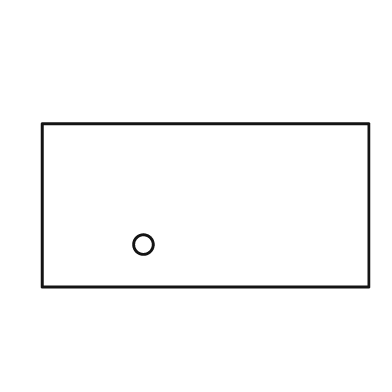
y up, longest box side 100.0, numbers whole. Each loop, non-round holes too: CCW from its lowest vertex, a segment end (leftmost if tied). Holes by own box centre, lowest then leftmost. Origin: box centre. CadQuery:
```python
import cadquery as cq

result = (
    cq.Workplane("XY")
    .moveTo(-50.0, -25.0)
    .lineTo(50.0, -25.0)
    .lineTo(50.0, 25.0)
    .lineTo(-50.0, 25.0)
    .close()
    .moveTo(-19.0, -12.0)
    .circle(3.0)
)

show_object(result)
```